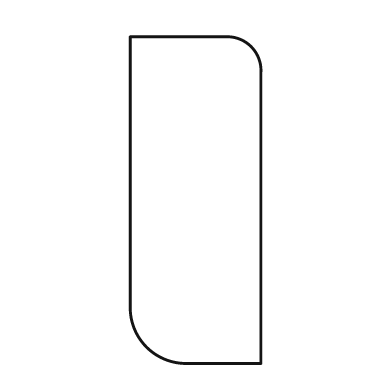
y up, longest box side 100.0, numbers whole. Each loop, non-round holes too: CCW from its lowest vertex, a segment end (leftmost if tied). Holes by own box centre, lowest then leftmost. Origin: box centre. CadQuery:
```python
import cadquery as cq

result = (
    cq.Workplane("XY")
    .moveTo(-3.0, -50.0)
    .lineTo(20.0, -50.0)
    .lineTo(20.0, 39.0)
    .threePointArc((17.0, 47.0), (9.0, 50.0))
    .lineTo(-20.0, 50.0)
    .lineTo(-20.0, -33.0)
    .threePointArc((-15.0, -45.0), (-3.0, -50.0))
    .close()
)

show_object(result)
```